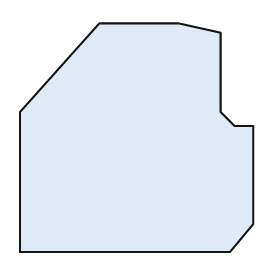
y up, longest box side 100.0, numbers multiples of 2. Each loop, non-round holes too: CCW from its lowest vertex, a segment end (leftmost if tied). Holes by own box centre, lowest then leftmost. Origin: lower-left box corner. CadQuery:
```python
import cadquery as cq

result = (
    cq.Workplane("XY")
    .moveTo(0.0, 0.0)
    .lineTo(90.0, 0.0)
    .lineTo(100.0, 12.0)
    .lineTo(100.0, 54.0)
    .lineTo(92.0, 54.0)
    .lineTo(86.0, 60.0)
    .lineTo(86.0, 94.0)
    .lineTo(68.0, 98.0)
    .lineTo(34.0, 98.0)
    .lineTo(0.0, 60.0)
    .close()
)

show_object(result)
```